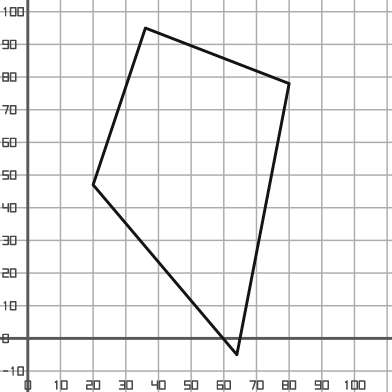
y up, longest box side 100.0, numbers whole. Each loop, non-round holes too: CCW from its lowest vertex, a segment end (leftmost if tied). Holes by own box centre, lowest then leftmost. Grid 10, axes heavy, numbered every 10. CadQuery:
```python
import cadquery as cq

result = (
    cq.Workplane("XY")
    .moveTo(64.0, -5.0)
    .lineTo(80.0, 78.0)
    .lineTo(36.0, 95.0)
    .lineTo(20.0, 47.0)
    .close()
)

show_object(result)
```